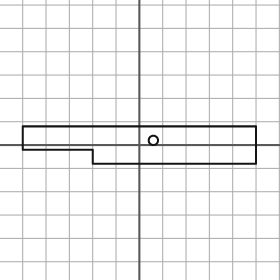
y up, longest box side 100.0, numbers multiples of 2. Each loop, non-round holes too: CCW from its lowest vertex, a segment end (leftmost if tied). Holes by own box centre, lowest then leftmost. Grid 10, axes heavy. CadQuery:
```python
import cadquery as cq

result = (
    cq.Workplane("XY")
    .moveTo(-20.0, -8.0)
    .lineTo(50.0, -8.0)
    .lineTo(50.0, 8.0)
    .lineTo(-50.0, 8.0)
    .lineTo(-50.0, -2.0)
    .lineTo(-20.0, -2.0)
    .close()
    .moveTo(6.0, 2.0)
    .circle(2.0)
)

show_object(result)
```